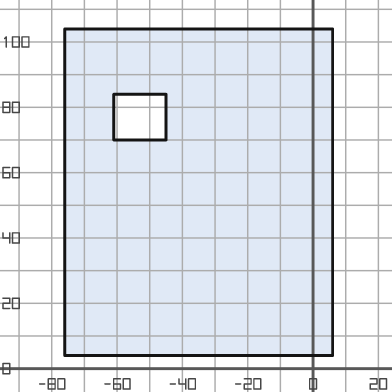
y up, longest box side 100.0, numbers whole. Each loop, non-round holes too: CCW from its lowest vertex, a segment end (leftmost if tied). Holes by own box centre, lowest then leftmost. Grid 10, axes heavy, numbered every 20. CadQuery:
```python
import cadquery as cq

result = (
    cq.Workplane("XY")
    .moveTo(-76.0, 4.0)
    .lineTo(6.0, 4.0)
    .lineTo(6.0, 104.0)
    .lineTo(-76.0, 104.0)
    .close()
    .moveTo(-61.0, 70.0)
    .lineTo(-45.0, 70.0)
    .lineTo(-45.0, 84.0)
    .lineTo(-61.0, 84.0)
    .close()
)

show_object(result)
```